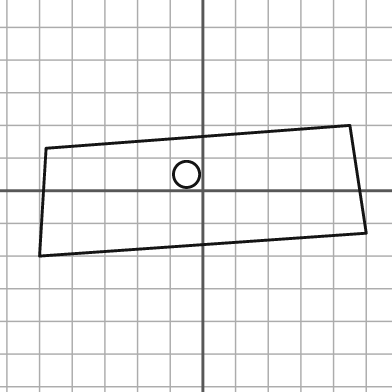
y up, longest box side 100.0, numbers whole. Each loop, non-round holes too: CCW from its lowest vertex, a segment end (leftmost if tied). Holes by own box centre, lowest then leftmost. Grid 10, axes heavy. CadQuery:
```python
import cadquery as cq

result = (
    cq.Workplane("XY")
    .moveTo(-50.0, -20.0)
    .lineTo(50.0, -13.0)
    .lineTo(45.0, 20.0)
    .lineTo(-48.0, 13.0)
    .close()
    .moveTo(-5.0, 5.0)
    .circle(4.0)
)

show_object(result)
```